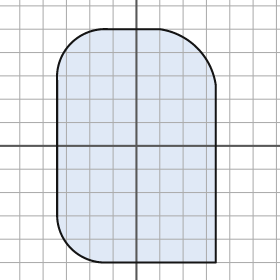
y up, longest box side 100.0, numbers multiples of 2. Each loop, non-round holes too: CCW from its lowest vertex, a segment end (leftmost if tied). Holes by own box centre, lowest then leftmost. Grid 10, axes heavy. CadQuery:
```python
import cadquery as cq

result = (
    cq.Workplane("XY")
    .moveTo(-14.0, -50.0)
    .lineTo(34.0, -50.0)
    .lineTo(34.0, 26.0)
    .threePointArc((26.0, 42.0), (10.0, 50.0))
    .lineTo(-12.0, 50.0)
    .threePointArc((-28.0, 44.0), (-34.0, 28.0))
    .lineTo(-34.0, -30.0)
    .threePointArc((-28.0, -44.0), (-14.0, -50.0))
    .close()
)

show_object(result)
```